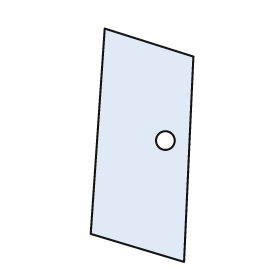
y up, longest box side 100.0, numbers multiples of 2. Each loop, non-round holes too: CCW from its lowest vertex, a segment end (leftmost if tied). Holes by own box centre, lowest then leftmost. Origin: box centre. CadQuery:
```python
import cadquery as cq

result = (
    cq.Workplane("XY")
    .moveTo(18.0, -50.0)
    .lineTo(22.0, 38.0)
    .lineTo(-16.0, 50.0)
    .lineTo(-22.0, -38.0)
    .close()
    .moveTo(10.0, 2.0)
    .circle(4.0)
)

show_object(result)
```